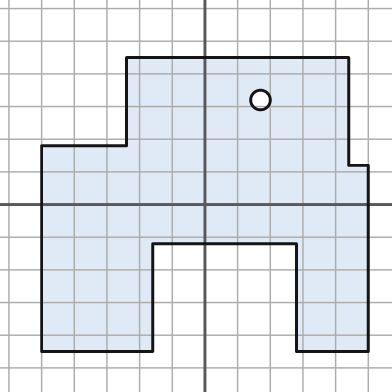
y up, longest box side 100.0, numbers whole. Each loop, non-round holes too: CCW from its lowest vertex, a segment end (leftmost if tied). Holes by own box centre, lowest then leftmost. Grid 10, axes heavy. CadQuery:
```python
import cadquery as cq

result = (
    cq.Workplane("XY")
    .moveTo(-50.0, -45.0)
    .lineTo(-16.0, -45.0)
    .lineTo(-16.0, -12.0)
    .lineTo(28.0, -12.0)
    .lineTo(28.0, -45.0)
    .lineTo(50.0, -45.0)
    .lineTo(50.0, 12.0)
    .lineTo(44.0, 12.0)
    .lineTo(44.0, 45.0)
    .lineTo(-24.0, 45.0)
    .lineTo(-24.0, 18.0)
    .lineTo(-50.0, 18.0)
    .close()
    .moveTo(17.0, 32.0)
    .circle(3.0)
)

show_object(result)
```